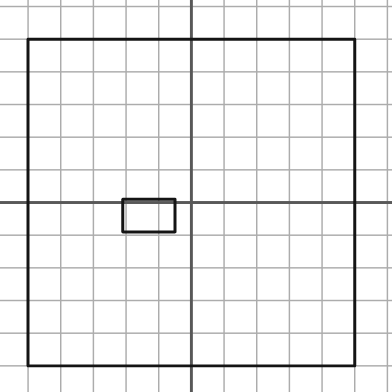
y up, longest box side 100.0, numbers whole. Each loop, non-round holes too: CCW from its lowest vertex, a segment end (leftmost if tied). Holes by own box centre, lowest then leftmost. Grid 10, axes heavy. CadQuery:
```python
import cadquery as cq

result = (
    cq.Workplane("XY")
    .moveTo(-50.0, -50.0)
    .lineTo(50.0, -50.0)
    .lineTo(50.0, 50.0)
    .lineTo(-50.0, 50.0)
    .close()
    .moveTo(-21.0, -9.0)
    .lineTo(-5.0, -9.0)
    .lineTo(-5.0, 1.0)
    .lineTo(-21.0, 1.0)
    .close()
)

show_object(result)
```